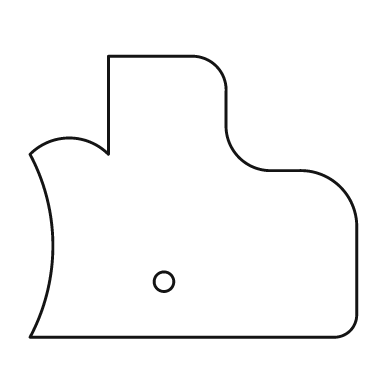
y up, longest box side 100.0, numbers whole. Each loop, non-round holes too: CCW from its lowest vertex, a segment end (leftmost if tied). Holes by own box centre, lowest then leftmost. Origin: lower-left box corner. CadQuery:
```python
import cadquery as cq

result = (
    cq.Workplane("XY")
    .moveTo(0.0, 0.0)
    .lineTo(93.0, 0.0)
    .threePointArc((98.0, 2.0), (100.0, 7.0))
    .lineTo(100.0, 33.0)
    .threePointArc((95.0, 46.0), (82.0, 51.0))
    .lineTo(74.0, 51.0)
    .threePointArc((64.0, 55.0), (60.0, 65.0))
    .lineTo(60.0, 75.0)
    .threePointArc((57.0, 83.0), (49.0, 86.0))
    .lineTo(24.0, 86.0)
    .lineTo(24.0, 56.0)
    .threePointArc((12.0, 61.0), (0.0, 56.0))
    .threePointArc((7.0, 28.0), (0.0, 0.0))
    .close()
    .moveTo(41.0, 17.0)
    .circle(3.0)
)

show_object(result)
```